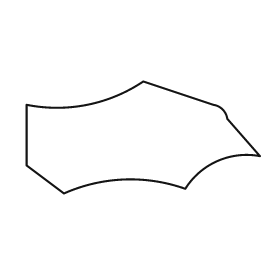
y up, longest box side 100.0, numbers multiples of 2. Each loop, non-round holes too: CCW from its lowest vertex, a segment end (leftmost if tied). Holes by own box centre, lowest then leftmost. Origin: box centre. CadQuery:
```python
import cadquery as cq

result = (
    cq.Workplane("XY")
    .moveTo(-34.0, -24.0)
    .threePointArc((-8.0, -18.0), (18.0, -22.0))
    .threePointArc((32.0, -10.0), (50.0, -8.0))
    .lineTo(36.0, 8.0)
    .threePointArc((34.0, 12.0), (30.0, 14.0))
    .lineTo(0.0, 24.0)
    .threePointArc((-24.0, 14.0), (-50.0, 14.0))
    .lineTo(-50.0, -12.0)
    .close()
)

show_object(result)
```